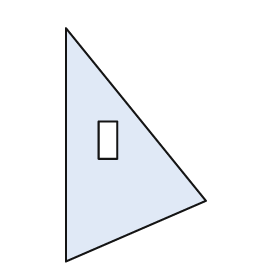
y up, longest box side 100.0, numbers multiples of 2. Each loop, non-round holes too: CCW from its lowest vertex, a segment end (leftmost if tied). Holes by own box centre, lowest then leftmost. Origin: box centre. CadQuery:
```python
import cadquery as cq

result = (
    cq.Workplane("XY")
    .moveTo(-30.0, -50.0)
    .lineTo(30.0, -24.0)
    .lineTo(-30.0, 50.0)
    .close()
    .moveTo(-16.0, -6.0)
    .lineTo(-8.0, -6.0)
    .lineTo(-8.0, 10.0)
    .lineTo(-16.0, 10.0)
    .close()
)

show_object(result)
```